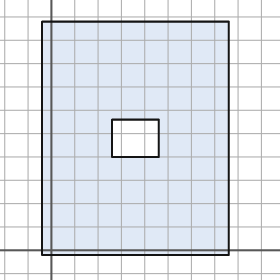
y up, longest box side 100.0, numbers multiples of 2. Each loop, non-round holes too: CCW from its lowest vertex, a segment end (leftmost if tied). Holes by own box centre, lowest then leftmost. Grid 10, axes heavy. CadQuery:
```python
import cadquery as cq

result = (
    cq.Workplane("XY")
    .moveTo(-4.0, -2.0)
    .lineTo(76.0, -2.0)
    .lineTo(76.0, 98.0)
    .lineTo(-4.0, 98.0)
    .close()
    .moveTo(26.0, 40.0)
    .lineTo(46.0, 40.0)
    .lineTo(46.0, 56.0)
    .lineTo(26.0, 56.0)
    .close()
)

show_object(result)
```